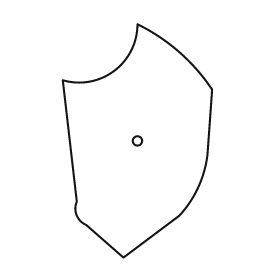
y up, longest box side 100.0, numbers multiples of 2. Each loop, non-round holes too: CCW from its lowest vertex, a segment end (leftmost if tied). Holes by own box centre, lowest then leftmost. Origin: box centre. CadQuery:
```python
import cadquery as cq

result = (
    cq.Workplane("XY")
    .moveTo(-6.0, -50.0)
    .lineTo(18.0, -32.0)
    .threePointArc((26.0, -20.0), (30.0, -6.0))
    .lineTo(32.0, 22.0)
    .threePointArc((18.0, 38.0), (0.0, 50.0))
    .threePointArc((-10.0, 30.0), (-32.0, 26.0))
    .lineTo(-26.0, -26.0)
    .threePointArc((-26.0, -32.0), (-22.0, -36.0))
    .close()
    .moveTo(0.0, 0.0)
    .circle(2.0)
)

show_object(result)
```